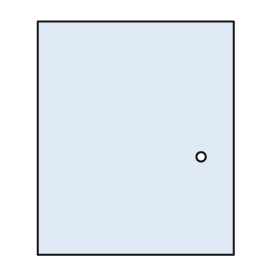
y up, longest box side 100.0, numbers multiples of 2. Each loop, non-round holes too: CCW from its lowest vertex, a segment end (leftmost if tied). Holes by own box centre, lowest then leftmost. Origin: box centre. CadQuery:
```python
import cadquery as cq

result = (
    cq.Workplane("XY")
    .moveTo(-42.0, -50.0)
    .lineTo(42.0, -50.0)
    .lineTo(42.0, 50.0)
    .lineTo(-42.0, 50.0)
    .close()
    .moveTo(28.0, -8.0)
    .circle(2.0)
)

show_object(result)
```